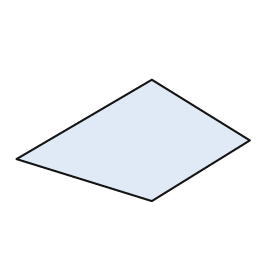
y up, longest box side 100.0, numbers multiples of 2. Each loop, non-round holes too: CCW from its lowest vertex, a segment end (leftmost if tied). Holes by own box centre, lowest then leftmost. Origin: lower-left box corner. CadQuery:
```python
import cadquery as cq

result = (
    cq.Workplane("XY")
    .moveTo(58.0, 0.0)
    .lineTo(100.0, 26.0)
    .lineTo(58.0, 52.0)
    .lineTo(0.0, 18.0)
    .close()
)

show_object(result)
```